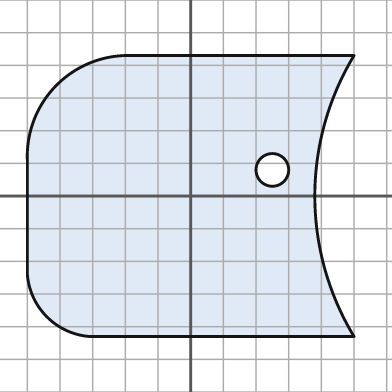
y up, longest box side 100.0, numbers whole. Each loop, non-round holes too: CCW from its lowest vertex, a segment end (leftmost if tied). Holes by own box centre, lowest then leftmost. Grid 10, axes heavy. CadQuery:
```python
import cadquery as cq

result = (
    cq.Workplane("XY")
    .moveTo(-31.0, -43.0)
    .lineTo(50.0, -43.0)
    .threePointArc((38.0, 0.0), (50.0, 43.0))
    .lineTo(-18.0, 43.0)
    .threePointArc((-41.0, 34.0), (-50.0, 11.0))
    .lineTo(-50.0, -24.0)
    .threePointArc((-44.0, -37.0), (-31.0, -43.0))
    .close()
    .moveTo(25.0, 8.0)
    .circle(5.0)
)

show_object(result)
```